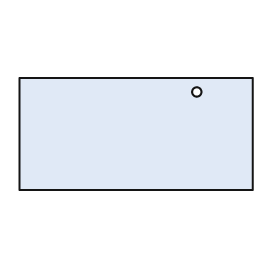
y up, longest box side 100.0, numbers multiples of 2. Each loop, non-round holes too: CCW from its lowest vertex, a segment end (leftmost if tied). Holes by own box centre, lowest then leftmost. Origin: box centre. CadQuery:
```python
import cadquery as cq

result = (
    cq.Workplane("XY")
    .moveTo(-50.0, -24.0)
    .lineTo(50.0, -24.0)
    .lineTo(50.0, 24.0)
    .lineTo(-50.0, 24.0)
    .close()
    .moveTo(26.0, 18.0)
    .circle(2.0)
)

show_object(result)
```